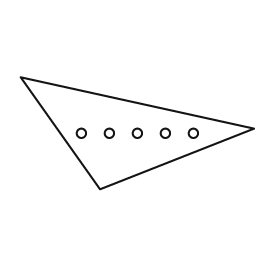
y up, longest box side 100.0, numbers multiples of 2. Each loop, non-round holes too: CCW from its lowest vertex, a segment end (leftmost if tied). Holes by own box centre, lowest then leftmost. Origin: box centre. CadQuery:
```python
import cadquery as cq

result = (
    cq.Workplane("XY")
    .moveTo(-16.0, -24.0)
    .lineTo(50.0, 2.0)
    .lineTo(-50.0, 24.0)
    .close()
    .moveTo(-24.0, 0.0)
    .circle(2.0)
    .moveTo(-12.0, 0.0)
    .circle(2.0)
    .moveTo(0.0, 0.0)
    .circle(2.0)
    .moveTo(12.0, 0.0)
    .circle(2.0)
    .moveTo(24.0, 0.0)
    .circle(2.0)
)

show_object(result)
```